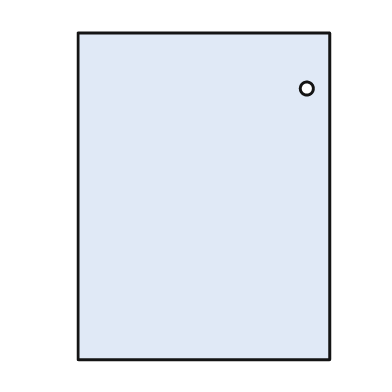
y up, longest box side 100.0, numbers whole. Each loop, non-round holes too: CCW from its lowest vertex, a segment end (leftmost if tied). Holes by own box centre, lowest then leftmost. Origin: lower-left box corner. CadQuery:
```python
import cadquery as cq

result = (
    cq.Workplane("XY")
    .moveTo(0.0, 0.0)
    .lineTo(77.0, 0.0)
    .lineTo(77.0, 100.0)
    .lineTo(0.0, 100.0)
    .close()
    .moveTo(70.0, 83.0)
    .circle(2.0)
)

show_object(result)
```